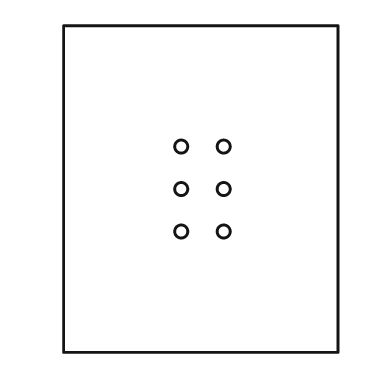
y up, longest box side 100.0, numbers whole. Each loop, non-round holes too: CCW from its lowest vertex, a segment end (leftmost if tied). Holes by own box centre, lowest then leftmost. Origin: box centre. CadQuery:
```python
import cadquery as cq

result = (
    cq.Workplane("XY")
    .moveTo(-42.0, -50.0)
    .lineTo(42.0, -50.0)
    .lineTo(42.0, 50.0)
    .lineTo(-42.0, 50.0)
    .close()
    .moveTo(-6.0, -13.0)
    .circle(2.0)
    .moveTo(7.0, -13.0)
    .circle(2.0)
    .moveTo(-6.0, 0.0)
    .circle(2.0)
    .moveTo(7.0, 0.0)
    .circle(2.0)
    .moveTo(-6.0, 13.0)
    .circle(2.0)
    .moveTo(7.0, 13.0)
    .circle(2.0)
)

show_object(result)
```